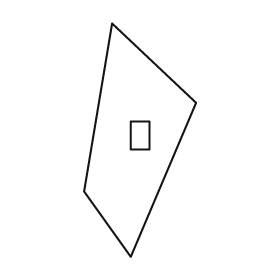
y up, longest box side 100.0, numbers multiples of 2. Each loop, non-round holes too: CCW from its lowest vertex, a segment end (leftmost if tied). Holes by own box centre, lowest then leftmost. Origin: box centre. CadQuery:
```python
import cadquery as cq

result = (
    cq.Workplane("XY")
    .moveTo(-4.0, -50.0)
    .lineTo(24.0, 16.0)
    .lineTo(-12.0, 50.0)
    .lineTo(-24.0, -22.0)
    .close()
    .moveTo(-4.0, -4.0)
    .lineTo(4.0, -4.0)
    .lineTo(4.0, 8.0)
    .lineTo(-4.0, 8.0)
    .close()
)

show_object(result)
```